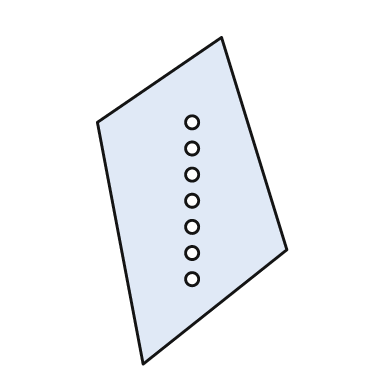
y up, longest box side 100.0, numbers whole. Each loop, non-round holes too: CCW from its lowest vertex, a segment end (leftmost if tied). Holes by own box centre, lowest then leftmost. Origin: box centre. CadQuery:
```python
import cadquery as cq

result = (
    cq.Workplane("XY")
    .moveTo(-15.0, -50.0)
    .lineTo(29.0, -15.0)
    .lineTo(9.0, 50.0)
    .lineTo(-29.0, 24.0)
    .close()
    .moveTo(0.0, -24.0)
    .circle(2.0)
    .moveTo(0.0, -16.0)
    .circle(2.0)
    .moveTo(0.0, -8.0)
    .circle(2.0)
    .moveTo(0.0, 0.0)
    .circle(2.0)
    .moveTo(0.0, 8.0)
    .circle(2.0)
    .moveTo(0.0, 16.0)
    .circle(2.0)
    .moveTo(0.0, 24.0)
    .circle(2.0)
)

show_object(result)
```